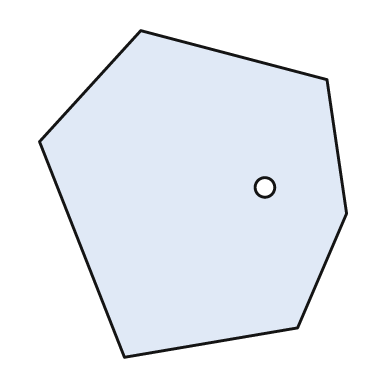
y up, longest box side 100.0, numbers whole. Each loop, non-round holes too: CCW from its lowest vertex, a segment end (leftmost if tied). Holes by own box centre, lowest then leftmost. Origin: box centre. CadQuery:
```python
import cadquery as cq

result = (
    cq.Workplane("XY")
    .moveTo(-21.0, -50.0)
    .lineTo(32.0, -41.0)
    .lineTo(47.0, -6.0)
    .lineTo(41.0, 35.0)
    .lineTo(-16.0, 50.0)
    .lineTo(-47.0, 16.0)
    .close()
    .moveTo(22.0, 2.0)
    .circle(3.0)
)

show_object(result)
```